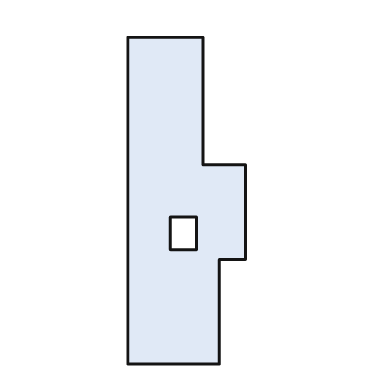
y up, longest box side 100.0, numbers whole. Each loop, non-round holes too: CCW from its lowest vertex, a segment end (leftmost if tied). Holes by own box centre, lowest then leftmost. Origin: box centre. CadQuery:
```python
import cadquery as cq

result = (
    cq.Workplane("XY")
    .moveTo(-18.0, -50.0)
    .lineTo(10.0, -50.0)
    .lineTo(10.0, -18.0)
    .lineTo(18.0, -18.0)
    .lineTo(18.0, 11.0)
    .lineTo(5.0, 11.0)
    .lineTo(5.0, 50.0)
    .lineTo(-18.0, 50.0)
    .close()
    .moveTo(-5.0, -15.0)
    .lineTo(3.0, -15.0)
    .lineTo(3.0, -5.0)
    .lineTo(-5.0, -5.0)
    .close()
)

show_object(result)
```